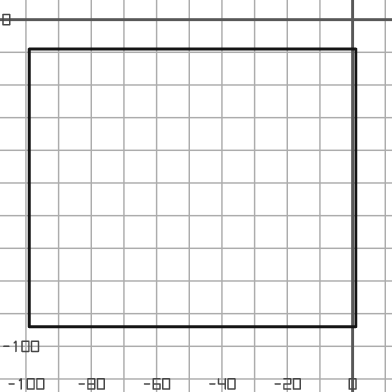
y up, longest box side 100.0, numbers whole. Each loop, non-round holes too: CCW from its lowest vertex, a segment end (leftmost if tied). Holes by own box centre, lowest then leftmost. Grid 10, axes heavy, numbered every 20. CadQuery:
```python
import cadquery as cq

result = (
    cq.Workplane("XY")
    .moveTo(-99.0, -94.0)
    .lineTo(1.0, -94.0)
    .lineTo(1.0, -9.0)
    .lineTo(-99.0, -9.0)
    .close()
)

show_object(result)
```